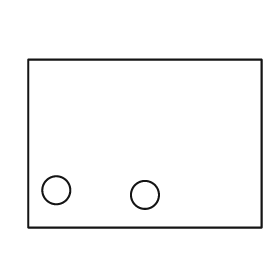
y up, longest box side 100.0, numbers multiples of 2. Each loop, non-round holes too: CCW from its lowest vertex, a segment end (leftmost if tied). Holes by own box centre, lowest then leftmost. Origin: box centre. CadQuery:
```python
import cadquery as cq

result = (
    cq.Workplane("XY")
    .moveTo(-50.0, -36.0)
    .lineTo(50.0, -36.0)
    .lineTo(50.0, 36.0)
    .lineTo(-50.0, 36.0)
    .close()
    .moveTo(0.0, -22.0)
    .circle(6.0)
    .moveTo(-38.0, -20.0)
    .circle(6.0)
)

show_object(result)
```